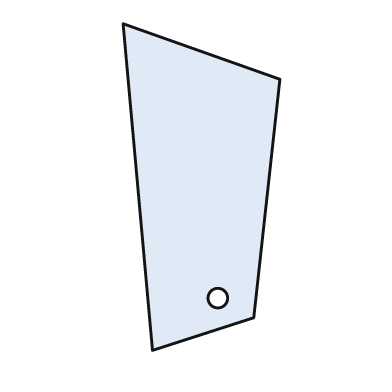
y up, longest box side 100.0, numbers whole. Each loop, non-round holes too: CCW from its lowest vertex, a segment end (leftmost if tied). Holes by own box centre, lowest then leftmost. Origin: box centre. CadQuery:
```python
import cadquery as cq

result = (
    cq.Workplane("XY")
    .moveTo(-15.0, -50.0)
    .lineTo(16.0, -40.0)
    .lineTo(24.0, 33.0)
    .lineTo(-24.0, 50.0)
    .close()
    .moveTo(5.0, -34.0)
    .circle(3.0)
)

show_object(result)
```